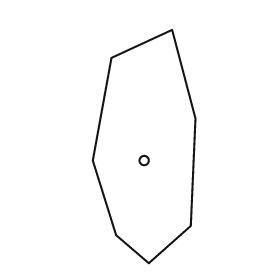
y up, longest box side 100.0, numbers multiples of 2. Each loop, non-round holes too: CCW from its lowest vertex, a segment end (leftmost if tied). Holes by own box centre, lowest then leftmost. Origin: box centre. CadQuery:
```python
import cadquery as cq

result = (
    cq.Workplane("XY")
    .moveTo(2.0, -50.0)
    .lineTo(20.0, -34.0)
    .lineTo(22.0, 12.0)
    .lineTo(12.0, 50.0)
    .lineTo(-14.0, 38.0)
    .lineTo(-22.0, -6.0)
    .lineTo(-12.0, -38.0)
    .close()
    .moveTo(0.0, -6.0)
    .circle(2.0)
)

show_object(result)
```